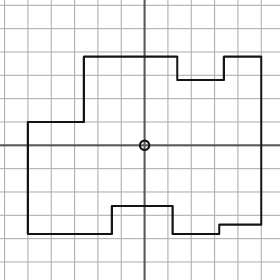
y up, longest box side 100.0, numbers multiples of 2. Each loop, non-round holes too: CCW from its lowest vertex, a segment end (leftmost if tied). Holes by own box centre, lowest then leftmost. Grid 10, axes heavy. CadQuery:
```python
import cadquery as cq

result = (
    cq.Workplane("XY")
    .moveTo(-50.0, -38.0)
    .lineTo(-14.0, -38.0)
    .lineTo(-14.0, -26.0)
    .lineTo(12.0, -26.0)
    .lineTo(12.0, -38.0)
    .lineTo(32.0, -38.0)
    .lineTo(32.0, -34.0)
    .lineTo(50.0, -34.0)
    .lineTo(50.0, 38.0)
    .lineTo(34.0, 38.0)
    .lineTo(34.0, 28.0)
    .lineTo(14.0, 28.0)
    .lineTo(14.0, 38.0)
    .lineTo(-26.0, 38.0)
    .lineTo(-26.0, 10.0)
    .lineTo(-50.0, 10.0)
    .close()
    .moveTo(0.0, 0.0)
    .circle(2.0)
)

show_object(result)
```